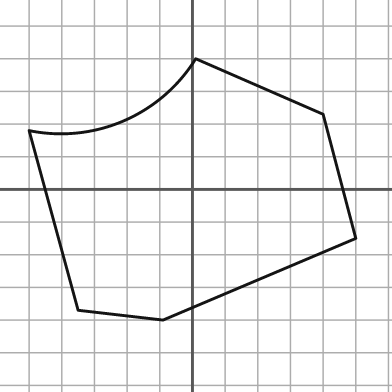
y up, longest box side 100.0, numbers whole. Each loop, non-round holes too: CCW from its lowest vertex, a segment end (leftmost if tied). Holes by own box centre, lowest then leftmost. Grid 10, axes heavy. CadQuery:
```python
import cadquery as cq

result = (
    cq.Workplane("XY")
    .moveTo(-9.0, -40.0)
    .lineTo(50.0, -15.0)
    .lineTo(40.0, 23.0)
    .lineTo(1.0, 40.0)
    .threePointArc((-21.0, 21.0), (-50.0, 18.0))
    .lineTo(-35.0, -37.0)
    .close()
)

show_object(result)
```